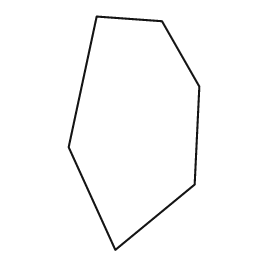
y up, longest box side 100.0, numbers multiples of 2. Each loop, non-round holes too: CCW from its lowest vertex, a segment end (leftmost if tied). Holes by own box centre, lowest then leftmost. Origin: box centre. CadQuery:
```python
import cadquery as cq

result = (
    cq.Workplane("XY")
    .moveTo(-8.0, -50.0)
    .lineTo(26.0, -22.0)
    .lineTo(28.0, 20.0)
    .lineTo(12.0, 48.0)
    .lineTo(-16.0, 50.0)
    .lineTo(-28.0, -6.0)
    .close()
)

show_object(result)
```